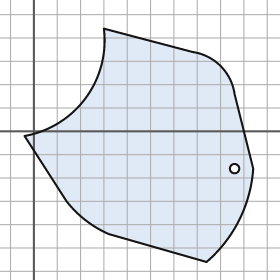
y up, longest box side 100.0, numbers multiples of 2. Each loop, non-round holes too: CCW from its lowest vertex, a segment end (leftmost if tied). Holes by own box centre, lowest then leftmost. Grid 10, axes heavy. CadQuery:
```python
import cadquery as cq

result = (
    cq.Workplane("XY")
    .moveTo(74.0, -56.0)
    .threePointArc((88.0, -38.0), (94.0, -16.0))
    .lineTo(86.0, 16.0)
    .threePointArc((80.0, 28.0), (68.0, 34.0))
    .lineTo(30.0, 44.0)
    .threePointArc((22.0, 14.0), (-4.0, -2.0))
    .lineTo(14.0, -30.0)
    .threePointArc((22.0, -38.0), (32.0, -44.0))
    .close()
    .moveTo(86.0, -16.0)
    .circle(2.0)
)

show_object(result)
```